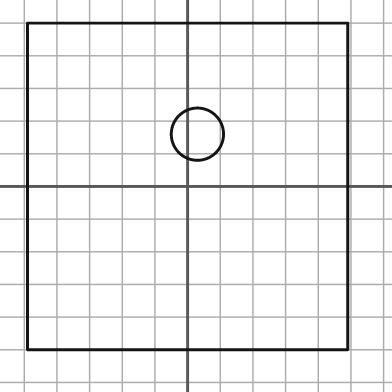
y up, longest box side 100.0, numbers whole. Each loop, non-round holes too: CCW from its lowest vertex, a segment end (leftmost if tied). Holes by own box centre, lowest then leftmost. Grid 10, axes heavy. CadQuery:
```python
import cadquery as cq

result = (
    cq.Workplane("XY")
    .moveTo(-49.0, -50.0)
    .lineTo(49.0, -50.0)
    .lineTo(49.0, 50.0)
    .lineTo(-49.0, 50.0)
    .close()
    .moveTo(3.0, 16.0)
    .circle(8.0)
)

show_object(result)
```